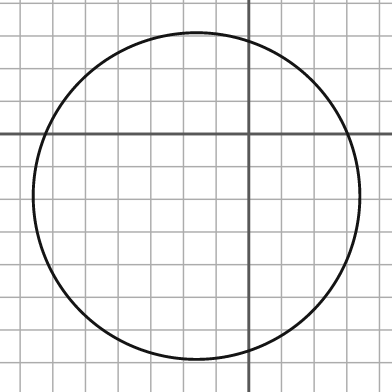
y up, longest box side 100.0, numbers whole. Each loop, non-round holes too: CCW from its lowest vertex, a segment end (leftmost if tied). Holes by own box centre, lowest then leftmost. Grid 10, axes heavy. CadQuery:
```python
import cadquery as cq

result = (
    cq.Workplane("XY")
    .moveTo(-16.0, -19.0)
    .circle(50.0)
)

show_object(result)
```